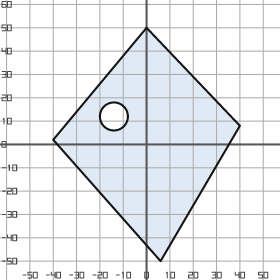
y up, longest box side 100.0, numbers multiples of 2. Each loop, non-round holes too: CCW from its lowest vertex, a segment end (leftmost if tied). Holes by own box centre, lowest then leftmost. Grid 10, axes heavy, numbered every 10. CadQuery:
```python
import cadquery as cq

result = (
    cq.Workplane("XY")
    .moveTo(6.0, -50.0)
    .lineTo(40.0, 8.0)
    .lineTo(0.0, 50.0)
    .lineTo(-40.0, 2.0)
    .close()
    .moveTo(-14.0, 12.0)
    .circle(6.0)
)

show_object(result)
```